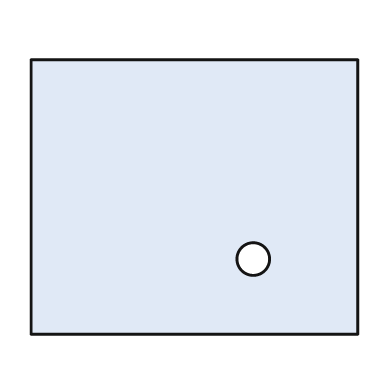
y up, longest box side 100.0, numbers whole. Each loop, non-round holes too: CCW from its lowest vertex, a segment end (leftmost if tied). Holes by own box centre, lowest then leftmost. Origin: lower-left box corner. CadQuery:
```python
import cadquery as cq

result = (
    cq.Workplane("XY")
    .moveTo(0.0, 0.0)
    .lineTo(100.0, 0.0)
    .lineTo(100.0, 84.0)
    .lineTo(0.0, 84.0)
    .close()
    .moveTo(68.0, 23.0)
    .circle(5.0)
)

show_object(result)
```